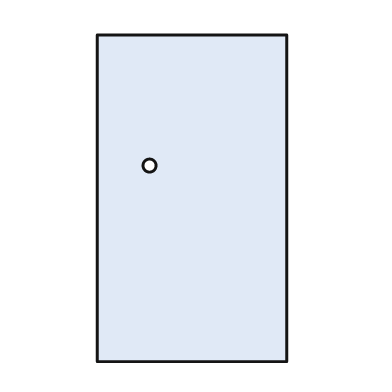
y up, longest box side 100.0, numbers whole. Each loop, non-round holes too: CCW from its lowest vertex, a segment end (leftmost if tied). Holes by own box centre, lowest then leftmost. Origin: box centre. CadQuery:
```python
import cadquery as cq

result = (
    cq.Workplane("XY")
    .moveTo(-29.0, -50.0)
    .lineTo(29.0, -50.0)
    .lineTo(29.0, 50.0)
    .lineTo(-29.0, 50.0)
    .close()
    .moveTo(-13.0, 10.0)
    .circle(2.0)
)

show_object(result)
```